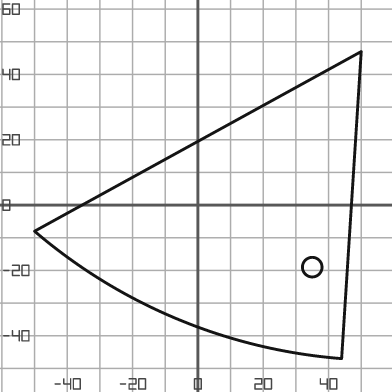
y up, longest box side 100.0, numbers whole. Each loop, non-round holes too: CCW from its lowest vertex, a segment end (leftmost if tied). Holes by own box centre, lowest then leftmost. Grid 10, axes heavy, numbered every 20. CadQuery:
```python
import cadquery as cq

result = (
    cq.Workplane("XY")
    .moveTo(44.0, -47.0)
    .lineTo(50.0, 47.0)
    .lineTo(-50.0, -8.0)
    .threePointArc((-6.0, -35.0), (44.0, -47.0))
    .close()
    .moveTo(35.0, -19.0)
    .circle(3.0)
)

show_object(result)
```